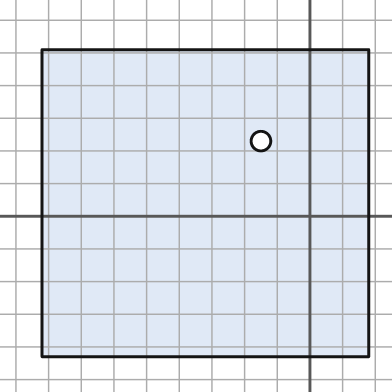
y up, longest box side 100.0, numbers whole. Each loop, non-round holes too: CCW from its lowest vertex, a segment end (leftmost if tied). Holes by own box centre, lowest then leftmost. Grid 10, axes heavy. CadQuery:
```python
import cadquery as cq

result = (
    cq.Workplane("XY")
    .moveTo(-82.0, -43.0)
    .lineTo(18.0, -43.0)
    .lineTo(18.0, 51.0)
    .lineTo(-82.0, 51.0)
    .close()
    .moveTo(-15.0, 23.0)
    .circle(3.0)
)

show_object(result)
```